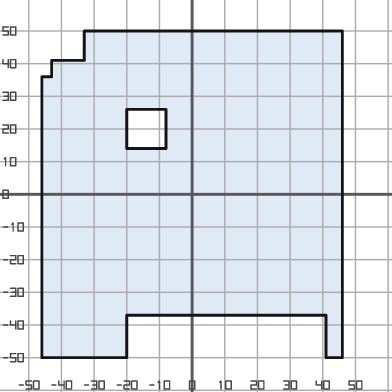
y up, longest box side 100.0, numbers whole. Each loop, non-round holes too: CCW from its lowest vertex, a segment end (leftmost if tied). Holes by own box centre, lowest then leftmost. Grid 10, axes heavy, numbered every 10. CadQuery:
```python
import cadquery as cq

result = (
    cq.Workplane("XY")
    .moveTo(-46.0, -50.0)
    .lineTo(-20.0, -50.0)
    .lineTo(-20.0, -37.0)
    .lineTo(41.0, -37.0)
    .lineTo(41.0, -50.0)
    .lineTo(46.0, -50.0)
    .lineTo(46.0, 50.0)
    .lineTo(-33.0, 50.0)
    .lineTo(-33.0, 41.0)
    .lineTo(-43.0, 41.0)
    .lineTo(-43.0, 36.0)
    .lineTo(-46.0, 36.0)
    .close()
    .moveTo(-20.0, 14.0)
    .lineTo(-8.0, 14.0)
    .lineTo(-8.0, 26.0)
    .lineTo(-20.0, 26.0)
    .close()
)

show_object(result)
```